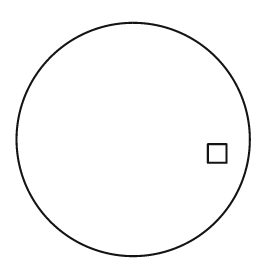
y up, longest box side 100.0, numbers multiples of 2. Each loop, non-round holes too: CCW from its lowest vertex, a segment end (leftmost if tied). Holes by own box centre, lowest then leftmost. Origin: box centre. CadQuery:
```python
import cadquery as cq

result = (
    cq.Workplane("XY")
    .moveTo(0.0, 0.0)
    .circle(50.0)
    .moveTo(32.0, -10.0)
    .lineTo(40.0, -10.0)
    .lineTo(40.0, -2.0)
    .lineTo(32.0, -2.0)
    .close()
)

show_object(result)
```